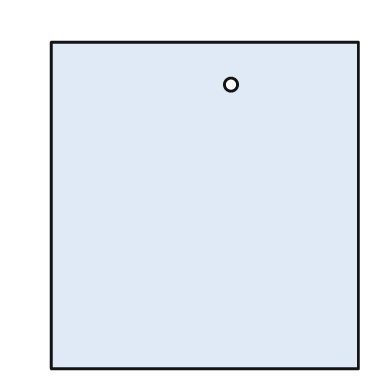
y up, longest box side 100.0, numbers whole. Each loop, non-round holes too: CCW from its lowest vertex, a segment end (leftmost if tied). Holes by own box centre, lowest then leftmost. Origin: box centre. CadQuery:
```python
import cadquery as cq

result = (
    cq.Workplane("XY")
    .moveTo(-47.0, -50.0)
    .lineTo(47.0, -50.0)
    .lineTo(47.0, 50.0)
    .lineTo(-47.0, 50.0)
    .close()
    .moveTo(8.0, 37.0)
    .circle(2.0)
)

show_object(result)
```